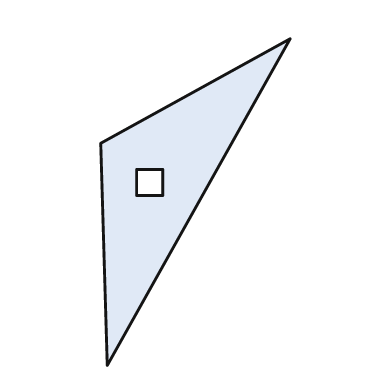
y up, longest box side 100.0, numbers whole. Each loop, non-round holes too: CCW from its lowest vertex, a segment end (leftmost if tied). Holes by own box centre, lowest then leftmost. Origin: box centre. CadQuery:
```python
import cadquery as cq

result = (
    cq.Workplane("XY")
    .moveTo(-27.0, -50.0)
    .lineTo(29.0, 50.0)
    .lineTo(-29.0, 18.0)
    .close()
    .moveTo(-18.0, 2.0)
    .lineTo(-10.0, 2.0)
    .lineTo(-10.0, 10.0)
    .lineTo(-18.0, 10.0)
    .close()
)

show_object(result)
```